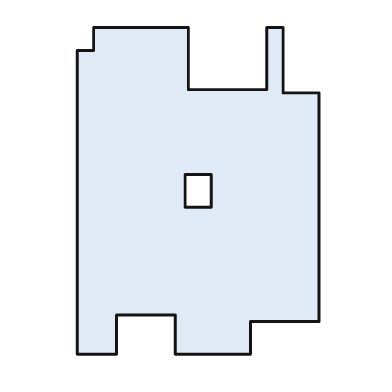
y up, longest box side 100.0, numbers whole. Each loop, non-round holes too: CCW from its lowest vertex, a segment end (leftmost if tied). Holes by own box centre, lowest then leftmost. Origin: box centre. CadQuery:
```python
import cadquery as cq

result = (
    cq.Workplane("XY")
    .moveTo(-37.0, -50.0)
    .lineTo(-25.0, -50.0)
    .lineTo(-25.0, -38.0)
    .lineTo(-7.0, -38.0)
    .lineTo(-7.0, -50.0)
    .lineTo(16.0, -50.0)
    .lineTo(16.0, -40.0)
    .lineTo(37.0, -40.0)
    .lineTo(37.0, 30.0)
    .lineTo(26.0, 30.0)
    .lineTo(26.0, 50.0)
    .lineTo(21.0, 50.0)
    .lineTo(21.0, 31.0)
    .lineTo(-3.0, 31.0)
    .lineTo(-3.0, 50.0)
    .lineTo(-32.0, 50.0)
    .lineTo(-32.0, 43.0)
    .lineTo(-37.0, 43.0)
    .close()
    .moveTo(-4.0, -5.0)
    .lineTo(4.0, -5.0)
    .lineTo(4.0, 5.0)
    .lineTo(-4.0, 5.0)
    .close()
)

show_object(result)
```